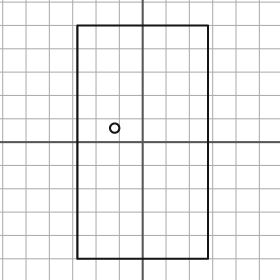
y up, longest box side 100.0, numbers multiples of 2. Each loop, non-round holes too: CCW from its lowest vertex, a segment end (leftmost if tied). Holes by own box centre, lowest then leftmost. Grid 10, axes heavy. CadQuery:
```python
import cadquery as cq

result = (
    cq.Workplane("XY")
    .moveTo(-28.0, -50.0)
    .lineTo(28.0, -50.0)
    .lineTo(28.0, 50.0)
    .lineTo(-28.0, 50.0)
    .close()
    .moveTo(-12.0, 6.0)
    .circle(2.0)
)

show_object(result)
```